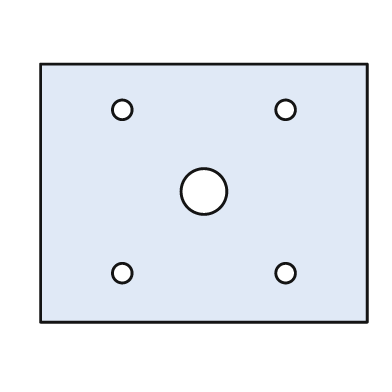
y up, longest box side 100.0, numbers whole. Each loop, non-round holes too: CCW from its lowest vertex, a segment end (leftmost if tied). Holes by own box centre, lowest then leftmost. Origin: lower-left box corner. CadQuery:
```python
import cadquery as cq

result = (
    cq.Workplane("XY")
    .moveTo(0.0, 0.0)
    .lineTo(100.0, 0.0)
    .lineTo(100.0, 79.0)
    .lineTo(0.0, 79.0)
    .close()
    .moveTo(25.0, 15.0)
    .circle(3.0)
    .moveTo(75.0, 15.0)
    .circle(3.0)
    .moveTo(50.0, 40.0)
    .circle(7.0)
    .moveTo(25.0, 65.0)
    .circle(3.0)
    .moveTo(75.0, 65.0)
    .circle(3.0)
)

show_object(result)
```